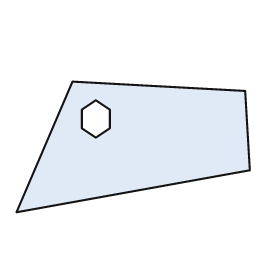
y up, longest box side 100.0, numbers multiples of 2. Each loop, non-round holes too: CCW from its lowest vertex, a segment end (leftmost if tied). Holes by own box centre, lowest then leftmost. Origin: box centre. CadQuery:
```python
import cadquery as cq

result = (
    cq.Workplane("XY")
    .moveTo(-50.0, -28.0)
    .lineTo(50.0, -10.0)
    .lineTo(48.0, 24.0)
    .lineTo(-26.0, 28.0)
    .close()
    .moveTo(-16.0, 4.0)
    .lineTo(-10.0, 8.0)
    .lineTo(-10.0, 16.0)
    .lineTo(-16.0, 20.0)
    .lineTo(-22.0, 16.0)
    .lineTo(-22.0, 8.0)
    .close()
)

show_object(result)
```